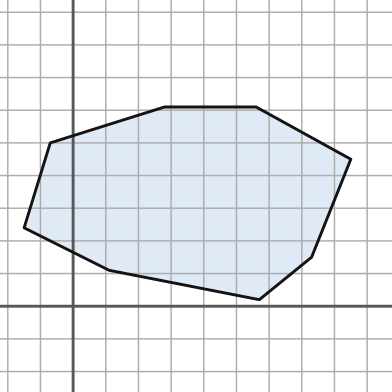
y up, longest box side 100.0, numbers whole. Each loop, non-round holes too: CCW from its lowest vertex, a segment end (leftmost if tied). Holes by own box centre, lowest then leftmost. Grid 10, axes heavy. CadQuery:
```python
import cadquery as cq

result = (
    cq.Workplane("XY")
    .moveTo(57.0, 2.0)
    .lineTo(73.0, 15.0)
    .lineTo(85.0, 45.0)
    .lineTo(56.0, 61.0)
    .lineTo(28.0, 61.0)
    .lineTo(-7.0, 50.0)
    .lineTo(-15.0, 24.0)
    .lineTo(11.0, 11.0)
    .close()
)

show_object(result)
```